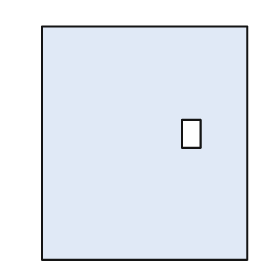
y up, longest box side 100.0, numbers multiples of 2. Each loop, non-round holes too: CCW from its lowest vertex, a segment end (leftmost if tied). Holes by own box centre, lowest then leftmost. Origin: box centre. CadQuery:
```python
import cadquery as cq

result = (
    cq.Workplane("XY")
    .moveTo(-44.0, -50.0)
    .lineTo(44.0, -50.0)
    .lineTo(44.0, 50.0)
    .lineTo(-44.0, 50.0)
    .close()
    .moveTo(16.0, -2.0)
    .lineTo(24.0, -2.0)
    .lineTo(24.0, 10.0)
    .lineTo(16.0, 10.0)
    .close()
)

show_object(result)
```